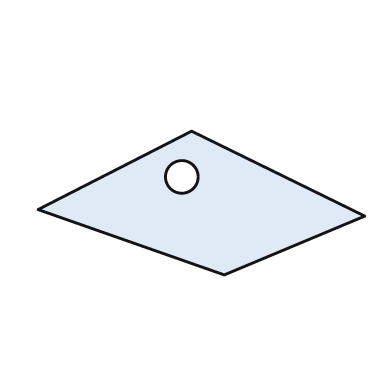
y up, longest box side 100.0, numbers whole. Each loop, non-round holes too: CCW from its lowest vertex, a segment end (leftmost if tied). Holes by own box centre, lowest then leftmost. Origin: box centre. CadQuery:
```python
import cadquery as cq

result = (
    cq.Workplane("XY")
    .moveTo(7.0, -22.0)
    .lineTo(50.0, -4.0)
    .lineTo(-3.0, 22.0)
    .lineTo(-50.0, -2.0)
    .close()
    .moveTo(-6.0, 8.0)
    .circle(5.0)
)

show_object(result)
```